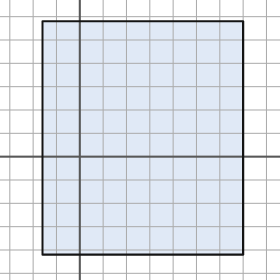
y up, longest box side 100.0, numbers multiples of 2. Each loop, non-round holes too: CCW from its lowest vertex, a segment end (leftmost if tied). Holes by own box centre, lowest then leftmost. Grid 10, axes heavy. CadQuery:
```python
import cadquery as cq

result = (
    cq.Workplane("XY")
    .moveTo(-16.0, -42.0)
    .lineTo(70.0, -42.0)
    .lineTo(70.0, 58.0)
    .lineTo(-16.0, 58.0)
    .close()
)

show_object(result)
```